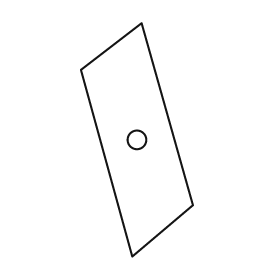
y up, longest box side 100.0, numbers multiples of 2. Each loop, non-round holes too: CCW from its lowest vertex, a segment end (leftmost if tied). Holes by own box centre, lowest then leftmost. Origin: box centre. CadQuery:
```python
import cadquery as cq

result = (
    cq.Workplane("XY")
    .moveTo(-2.0, -50.0)
    .lineTo(24.0, -28.0)
    .lineTo(2.0, 50.0)
    .lineTo(-24.0, 30.0)
    .close()
    .moveTo(0.0, 0.0)
    .circle(4.0)
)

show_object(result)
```